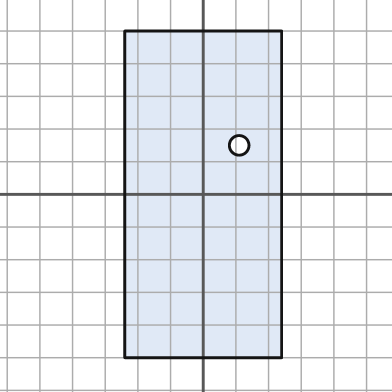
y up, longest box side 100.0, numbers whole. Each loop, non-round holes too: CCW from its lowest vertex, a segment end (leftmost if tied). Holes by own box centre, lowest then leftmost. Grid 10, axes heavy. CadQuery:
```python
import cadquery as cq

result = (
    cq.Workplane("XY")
    .moveTo(-24.0, -50.0)
    .lineTo(24.0, -50.0)
    .lineTo(24.0, 50.0)
    .lineTo(-24.0, 50.0)
    .close()
    .moveTo(11.0, 15.0)
    .circle(3.0)
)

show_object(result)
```